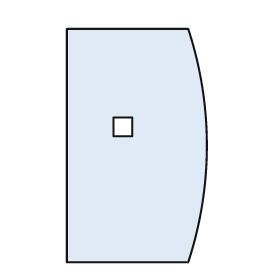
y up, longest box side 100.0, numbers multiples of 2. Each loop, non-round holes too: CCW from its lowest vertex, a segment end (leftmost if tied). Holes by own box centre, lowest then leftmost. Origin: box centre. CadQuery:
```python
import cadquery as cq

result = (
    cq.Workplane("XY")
    .moveTo(-30.0, -50.0)
    .lineTo(22.0, -50.0)
    .threePointArc((30.0, 0.0), (22.0, 50.0))
    .lineTo(-30.0, 50.0)
    .close()
    .moveTo(-10.0, 4.0)
    .lineTo(-2.0, 4.0)
    .lineTo(-2.0, 12.0)
    .lineTo(-10.0, 12.0)
    .close()
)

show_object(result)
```